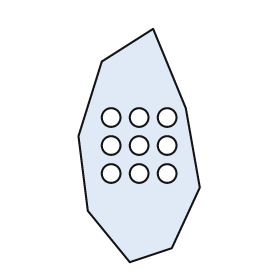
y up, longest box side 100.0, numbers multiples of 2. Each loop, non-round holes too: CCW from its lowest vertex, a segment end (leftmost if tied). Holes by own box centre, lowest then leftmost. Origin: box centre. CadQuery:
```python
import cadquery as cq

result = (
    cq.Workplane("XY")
    .moveTo(-4.0, -50.0)
    .lineTo(14.0, -44.0)
    .lineTo(26.0, -18.0)
    .lineTo(20.0, 16.0)
    .lineTo(6.0, 50.0)
    .lineTo(-16.0, 36.0)
    .lineTo(-26.0, 4.0)
    .lineTo(-22.0, -28.0)
    .close()
    .moveTo(-12.0, -12.0)
    .circle(4.0)
    .moveTo(0.0, -12.0)
    .circle(4.0)
    .moveTo(12.0, -12.0)
    .circle(4.0)
    .moveTo(-12.0, 0.0)
    .circle(4.0)
    .moveTo(0.0, 0.0)
    .circle(4.0)
    .moveTo(12.0, 0.0)
    .circle(4.0)
    .moveTo(-12.0, 12.0)
    .circle(4.0)
    .moveTo(0.0, 12.0)
    .circle(4.0)
    .moveTo(12.0, 12.0)
    .circle(4.0)
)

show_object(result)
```